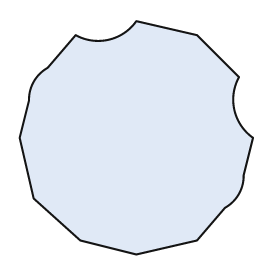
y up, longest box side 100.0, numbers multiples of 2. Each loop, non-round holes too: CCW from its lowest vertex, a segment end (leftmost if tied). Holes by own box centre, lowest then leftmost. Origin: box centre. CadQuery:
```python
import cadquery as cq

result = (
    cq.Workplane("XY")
    .moveTo(0.0, -50.0)
    .lineTo(26.0, -44.0)
    .lineTo(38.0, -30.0)
    .threePointArc((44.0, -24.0), (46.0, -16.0))
    .lineTo(50.0, 0.0)
    .threePointArc((42.0, 12.0), (44.0, 26.0))
    .lineTo(26.0, 44.0)
    .lineTo(0.0, 50.0)
    .threePointArc((-12.0, 42.0), (-26.0, 44.0))
    .lineTo(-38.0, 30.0)
    .threePointArc((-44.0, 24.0), (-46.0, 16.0))
    .lineTo(-50.0, 0.0)
    .lineTo(-44.0, -26.0)
    .lineTo(-24.0, -44.0)
    .close()
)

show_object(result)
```